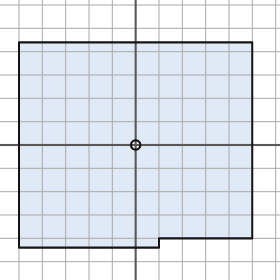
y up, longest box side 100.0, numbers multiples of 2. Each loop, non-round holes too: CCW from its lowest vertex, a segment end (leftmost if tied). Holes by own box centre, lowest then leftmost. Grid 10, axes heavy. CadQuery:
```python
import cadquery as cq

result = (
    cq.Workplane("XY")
    .moveTo(-50.0, -44.0)
    .lineTo(10.0, -44.0)
    .lineTo(10.0, -40.0)
    .lineTo(50.0, -40.0)
    .lineTo(50.0, 44.0)
    .lineTo(-50.0, 44.0)
    .close()
    .moveTo(0.0, 0.0)
    .circle(2.0)
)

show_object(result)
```